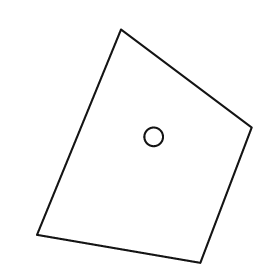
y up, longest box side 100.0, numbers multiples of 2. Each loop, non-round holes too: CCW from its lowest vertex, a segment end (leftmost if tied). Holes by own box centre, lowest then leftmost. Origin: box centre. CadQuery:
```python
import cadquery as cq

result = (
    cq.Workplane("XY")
    .moveTo(24.0, -50.0)
    .lineTo(46.0, 8.0)
    .lineTo(-10.0, 50.0)
    .lineTo(-46.0, -38.0)
    .close()
    .moveTo(4.0, 4.0)
    .circle(4.0)
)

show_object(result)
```